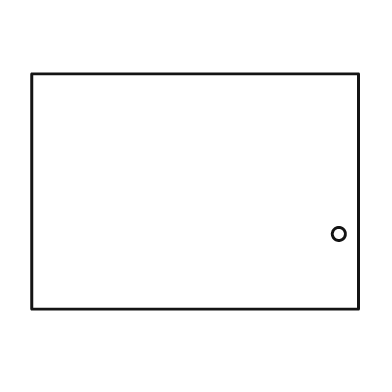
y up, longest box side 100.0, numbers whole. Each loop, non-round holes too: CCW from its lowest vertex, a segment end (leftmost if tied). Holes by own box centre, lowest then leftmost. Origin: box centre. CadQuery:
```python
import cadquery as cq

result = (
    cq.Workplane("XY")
    .moveTo(-50.0, -36.0)
    .lineTo(50.0, -36.0)
    .lineTo(50.0, 36.0)
    .lineTo(-50.0, 36.0)
    .close()
    .moveTo(44.0, -13.0)
    .circle(2.0)
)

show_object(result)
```